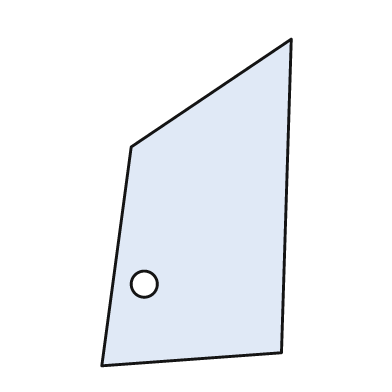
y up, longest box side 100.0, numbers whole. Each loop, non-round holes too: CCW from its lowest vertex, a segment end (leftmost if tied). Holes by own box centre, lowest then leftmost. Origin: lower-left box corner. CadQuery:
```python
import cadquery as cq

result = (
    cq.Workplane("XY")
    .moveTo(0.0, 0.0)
    .lineTo(55.0, 4.0)
    .lineTo(58.0, 100.0)
    .lineTo(9.0, 67.0)
    .close()
    .moveTo(13.0, 25.0)
    .circle(4.0)
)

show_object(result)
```